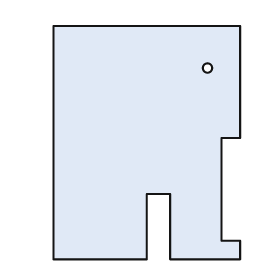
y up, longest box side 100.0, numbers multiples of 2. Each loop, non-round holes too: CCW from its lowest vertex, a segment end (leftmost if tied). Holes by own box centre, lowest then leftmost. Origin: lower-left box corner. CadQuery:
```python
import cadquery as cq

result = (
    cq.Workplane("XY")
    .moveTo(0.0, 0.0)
    .lineTo(40.0, 0.0)
    .lineTo(40.0, 28.0)
    .lineTo(50.0, 28.0)
    .lineTo(50.0, 0.0)
    .lineTo(80.0, 0.0)
    .lineTo(80.0, 8.0)
    .lineTo(72.0, 8.0)
    .lineTo(72.0, 52.0)
    .lineTo(80.0, 52.0)
    .lineTo(80.0, 100.0)
    .lineTo(0.0, 100.0)
    .close()
    .moveTo(66.0, 82.0)
    .circle(2.0)
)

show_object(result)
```